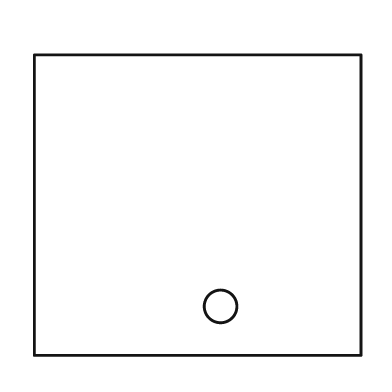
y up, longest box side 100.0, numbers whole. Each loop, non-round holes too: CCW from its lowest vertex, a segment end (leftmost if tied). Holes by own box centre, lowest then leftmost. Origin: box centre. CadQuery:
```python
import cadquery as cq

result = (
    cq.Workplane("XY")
    .moveTo(-50.0, -46.0)
    .lineTo(50.0, -46.0)
    .lineTo(50.0, 46.0)
    .lineTo(-50.0, 46.0)
    .close()
    .moveTo(7.0, -31.0)
    .circle(5.0)
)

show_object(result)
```